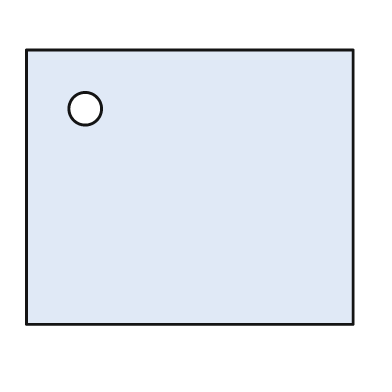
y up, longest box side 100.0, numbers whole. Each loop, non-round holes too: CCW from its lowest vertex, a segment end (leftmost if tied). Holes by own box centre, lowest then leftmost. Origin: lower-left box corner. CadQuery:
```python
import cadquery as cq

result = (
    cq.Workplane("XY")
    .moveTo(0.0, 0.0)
    .lineTo(100.0, 0.0)
    .lineTo(100.0, 84.0)
    .lineTo(0.0, 84.0)
    .close()
    .moveTo(18.0, 66.0)
    .circle(5.0)
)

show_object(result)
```